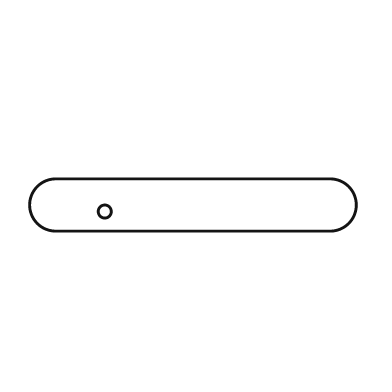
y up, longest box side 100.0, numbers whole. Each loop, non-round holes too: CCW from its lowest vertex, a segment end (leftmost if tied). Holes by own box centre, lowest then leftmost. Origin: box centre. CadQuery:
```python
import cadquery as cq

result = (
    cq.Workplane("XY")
    .moveTo(-42.0, -8.0)
    .lineTo(42.0, -8.0)
    .threePointArc((50.0, 0.0), (42.0, 8.0))
    .lineTo(-42.0, 8.0)
    .threePointArc((-50.0, 0.0), (-42.0, -8.0))
    .close()
    .moveTo(-27.0, -2.0)
    .circle(2.0)
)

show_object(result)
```